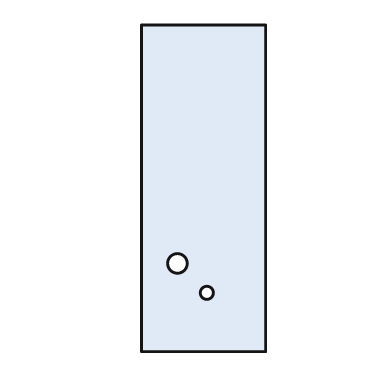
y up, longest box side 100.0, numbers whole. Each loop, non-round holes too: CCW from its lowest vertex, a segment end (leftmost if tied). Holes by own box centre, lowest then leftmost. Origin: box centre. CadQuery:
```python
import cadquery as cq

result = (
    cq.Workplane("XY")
    .moveTo(-19.0, -50.0)
    .lineTo(19.0, -50.0)
    .lineTo(19.0, 50.0)
    .lineTo(-19.0, 50.0)
    .close()
    .moveTo(1.0, -32.0)
    .circle(2.0)
    .moveTo(-8.0, -23.0)
    .circle(3.0)
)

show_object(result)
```